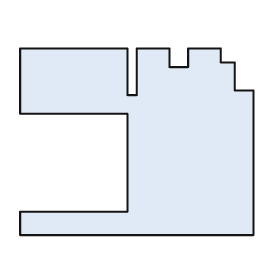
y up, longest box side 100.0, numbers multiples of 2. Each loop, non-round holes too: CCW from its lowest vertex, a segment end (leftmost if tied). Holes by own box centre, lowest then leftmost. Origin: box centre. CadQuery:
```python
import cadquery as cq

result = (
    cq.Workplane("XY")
    .moveTo(-50.0, -40.0)
    .lineTo(50.0, -40.0)
    .lineTo(50.0, 22.0)
    .lineTo(42.0, 22.0)
    .lineTo(42.0, 34.0)
    .lineTo(36.0, 34.0)
    .lineTo(36.0, 40.0)
    .lineTo(22.0, 40.0)
    .lineTo(22.0, 32.0)
    .lineTo(14.0, 32.0)
    .lineTo(14.0, 40.0)
    .lineTo(0.0, 40.0)
    .lineTo(0.0, 20.0)
    .lineTo(-4.0, 20.0)
    .lineTo(-4.0, 40.0)
    .lineTo(-50.0, 40.0)
    .lineTo(-50.0, 12.0)
    .lineTo(-4.0, 12.0)
    .lineTo(-4.0, -30.0)
    .lineTo(-50.0, -30.0)
    .close()
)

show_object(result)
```